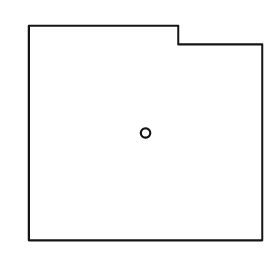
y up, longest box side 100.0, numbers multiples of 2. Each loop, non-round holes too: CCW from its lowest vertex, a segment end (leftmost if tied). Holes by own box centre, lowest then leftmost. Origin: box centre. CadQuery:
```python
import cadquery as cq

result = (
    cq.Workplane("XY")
    .moveTo(-50.0, -46.0)
    .lineTo(50.0, -46.0)
    .lineTo(50.0, 38.0)
    .lineTo(14.0, 38.0)
    .lineTo(14.0, 46.0)
    .lineTo(-50.0, 46.0)
    .close()
    .moveTo(0.0, 0.0)
    .circle(2.0)
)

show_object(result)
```